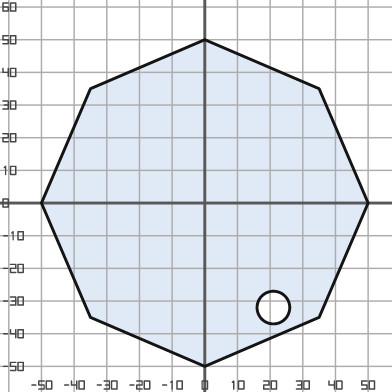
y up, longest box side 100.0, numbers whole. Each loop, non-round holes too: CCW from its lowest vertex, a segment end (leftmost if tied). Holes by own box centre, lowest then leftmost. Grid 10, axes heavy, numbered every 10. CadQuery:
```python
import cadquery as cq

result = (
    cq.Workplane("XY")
    .moveTo(0.0, -50.0)
    .lineTo(35.0, -35.0)
    .lineTo(50.0, 0.0)
    .lineTo(35.0, 35.0)
    .lineTo(0.0, 50.0)
    .lineTo(-35.0, 35.0)
    .lineTo(-50.0, 0.0)
    .lineTo(-35.0, -35.0)
    .close()
    .moveTo(21.0, -32.0)
    .circle(5.0)
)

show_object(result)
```